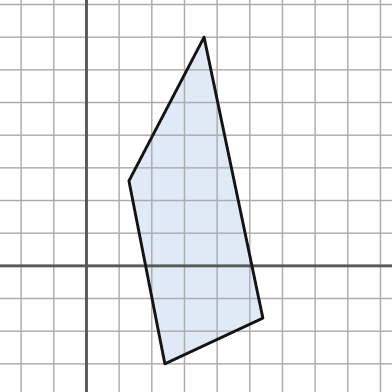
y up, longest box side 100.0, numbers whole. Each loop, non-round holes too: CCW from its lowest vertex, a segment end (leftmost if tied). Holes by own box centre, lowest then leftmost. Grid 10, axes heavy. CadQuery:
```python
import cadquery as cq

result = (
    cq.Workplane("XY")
    .moveTo(24.0, -30.0)
    .lineTo(54.0, -16.0)
    .lineTo(36.0, 70.0)
    .lineTo(13.0, 26.0)
    .close()
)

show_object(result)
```